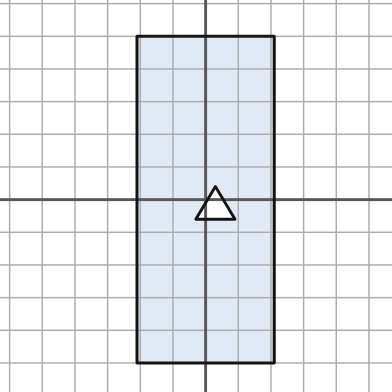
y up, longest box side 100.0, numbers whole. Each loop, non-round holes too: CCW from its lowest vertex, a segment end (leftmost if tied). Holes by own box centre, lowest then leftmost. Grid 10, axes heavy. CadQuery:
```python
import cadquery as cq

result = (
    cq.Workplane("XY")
    .moveTo(-21.0, -50.0)
    .lineTo(21.0, -50.0)
    .lineTo(21.0, 50.0)
    .lineTo(-21.0, 50.0)
    .close()
    .moveTo(-3.0, -6.0)
    .lineTo(9.0, -6.0)
    .lineTo(3.0, 4.0)
    .close()
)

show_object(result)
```